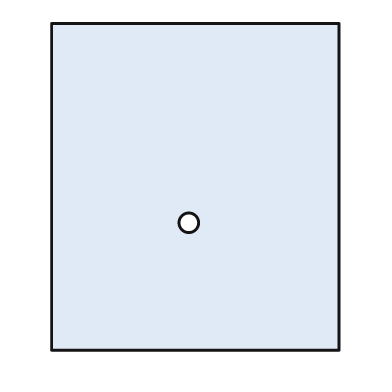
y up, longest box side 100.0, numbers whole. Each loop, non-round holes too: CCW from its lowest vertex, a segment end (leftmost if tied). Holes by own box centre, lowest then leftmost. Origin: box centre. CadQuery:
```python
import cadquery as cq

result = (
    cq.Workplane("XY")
    .moveTo(-44.0, -50.0)
    .lineTo(44.0, -50.0)
    .lineTo(44.0, 50.0)
    .lineTo(-44.0, 50.0)
    .close()
    .moveTo(-2.0, -11.0)
    .circle(3.0)
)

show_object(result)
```